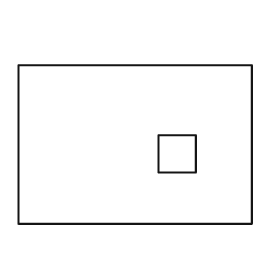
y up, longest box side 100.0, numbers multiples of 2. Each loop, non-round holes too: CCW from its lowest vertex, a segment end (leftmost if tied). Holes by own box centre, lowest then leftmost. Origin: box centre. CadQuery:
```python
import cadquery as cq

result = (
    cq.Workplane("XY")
    .moveTo(-50.0, -34.0)
    .lineTo(50.0, -34.0)
    .lineTo(50.0, 34.0)
    .lineTo(-50.0, 34.0)
    .close()
    .moveTo(10.0, -12.0)
    .lineTo(26.0, -12.0)
    .lineTo(26.0, 4.0)
    .lineTo(10.0, 4.0)
    .close()
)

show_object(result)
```